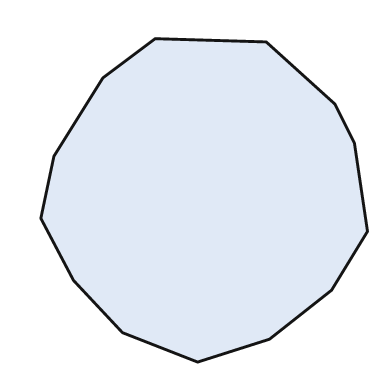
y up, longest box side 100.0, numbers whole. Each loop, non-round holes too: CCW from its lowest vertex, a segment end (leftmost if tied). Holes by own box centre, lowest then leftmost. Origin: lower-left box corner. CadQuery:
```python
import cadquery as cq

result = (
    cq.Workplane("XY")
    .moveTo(48.0, 0.0)
    .lineTo(70.0, 7.0)
    .lineTo(89.0, 22.0)
    .lineTo(100.0, 40.0)
    .lineTo(96.0, 67.0)
    .lineTo(90.0, 79.0)
    .lineTo(69.0, 98.0)
    .lineTo(35.0, 99.0)
    .lineTo(19.0, 87.0)
    .lineTo(4.0, 63.0)
    .lineTo(0.0, 44.0)
    .lineTo(10.0, 25.0)
    .lineTo(25.0, 9.0)
    .close()
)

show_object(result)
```